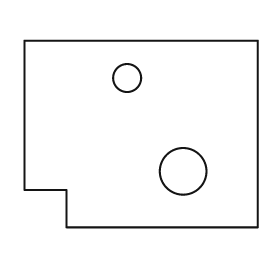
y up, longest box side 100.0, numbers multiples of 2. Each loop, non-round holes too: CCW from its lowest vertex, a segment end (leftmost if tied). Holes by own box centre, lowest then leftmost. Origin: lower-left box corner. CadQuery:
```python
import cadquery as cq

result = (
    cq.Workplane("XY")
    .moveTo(18.0, 0.0)
    .lineTo(100.0, 0.0)
    .lineTo(100.0, 80.0)
    .lineTo(0.0, 80.0)
    .lineTo(0.0, 16.0)
    .lineTo(18.0, 16.0)
    .close()
    .moveTo(68.0, 24.0)
    .circle(10.0)
    .moveTo(44.0, 64.0)
    .circle(6.0)
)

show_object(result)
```